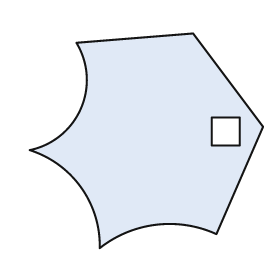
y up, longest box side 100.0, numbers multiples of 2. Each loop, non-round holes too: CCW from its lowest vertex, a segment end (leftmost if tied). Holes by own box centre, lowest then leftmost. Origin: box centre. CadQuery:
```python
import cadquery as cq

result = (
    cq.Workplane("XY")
    .moveTo(-20.0, -46.0)
    .threePointArc((4.0, -36.0), (30.0, -40.0))
    .lineTo(50.0, 6.0)
    .lineTo(20.0, 46.0)
    .lineTo(-30.0, 42.0)
    .threePointArc((-28.0, 14.0), (-50.0, -4.0))
    .threePointArc((-28.0, -20.0), (-20.0, -46.0))
    .close()
    .moveTo(28.0, -2.0)
    .lineTo(40.0, -2.0)
    .lineTo(40.0, 10.0)
    .lineTo(28.0, 10.0)
    .close()
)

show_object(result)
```